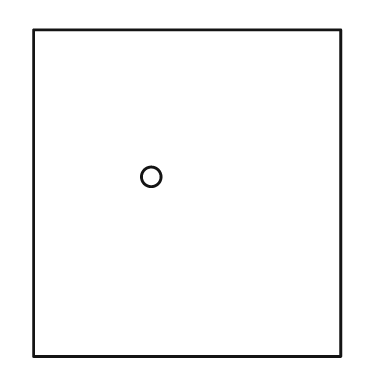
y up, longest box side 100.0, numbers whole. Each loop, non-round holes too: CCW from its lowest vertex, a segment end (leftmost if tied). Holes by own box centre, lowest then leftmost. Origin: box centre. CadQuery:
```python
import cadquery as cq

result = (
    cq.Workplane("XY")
    .moveTo(-47.0, -50.0)
    .lineTo(47.0, -50.0)
    .lineTo(47.0, 50.0)
    .lineTo(-47.0, 50.0)
    .close()
    .moveTo(-11.0, 5.0)
    .circle(3.0)
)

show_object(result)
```